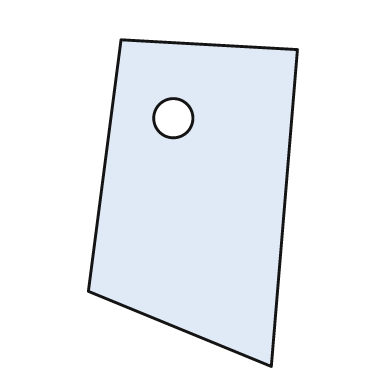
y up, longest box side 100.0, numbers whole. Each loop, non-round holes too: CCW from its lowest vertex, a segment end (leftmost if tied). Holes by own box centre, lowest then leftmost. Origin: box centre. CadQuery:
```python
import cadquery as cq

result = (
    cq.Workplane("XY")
    .moveTo(24.0, -50.0)
    .lineTo(32.0, 47.0)
    .lineTo(-22.0, 50.0)
    .lineTo(-32.0, -27.0)
    .close()
    .moveTo(-6.0, 26.0)
    .circle(6.0)
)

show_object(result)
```